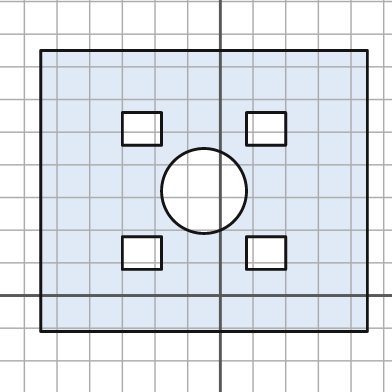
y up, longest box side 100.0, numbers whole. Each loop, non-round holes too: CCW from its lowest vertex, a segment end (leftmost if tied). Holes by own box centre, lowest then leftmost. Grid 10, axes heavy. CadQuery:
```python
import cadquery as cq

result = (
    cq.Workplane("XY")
    .moveTo(-55.0, -11.0)
    .lineTo(45.0, -11.0)
    .lineTo(45.0, 75.0)
    .lineTo(-55.0, 75.0)
    .close()
    .moveTo(-30.0, 8.0)
    .lineTo(-18.0, 8.0)
    .lineTo(-18.0, 18.0)
    .lineTo(-30.0, 18.0)
    .close()
    .moveTo(8.0, 8.0)
    .lineTo(20.0, 8.0)
    .lineTo(20.0, 18.0)
    .lineTo(8.0, 18.0)
    .close()
    .moveTo(-5.0, 32.0)
    .circle(13.0)
    .moveTo(-30.0, 46.0)
    .lineTo(-18.0, 46.0)
    .lineTo(-18.0, 56.0)
    .lineTo(-30.0, 56.0)
    .close()
    .moveTo(8.0, 46.0)
    .lineTo(20.0, 46.0)
    .lineTo(20.0, 56.0)
    .lineTo(8.0, 56.0)
    .close()
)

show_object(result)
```